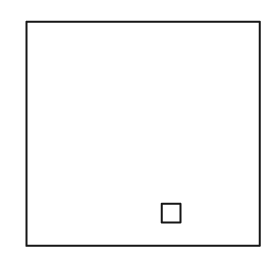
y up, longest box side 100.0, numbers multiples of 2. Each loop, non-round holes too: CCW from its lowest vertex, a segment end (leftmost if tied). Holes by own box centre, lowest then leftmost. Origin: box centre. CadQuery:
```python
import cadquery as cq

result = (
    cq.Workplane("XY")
    .moveTo(-50.0, -48.0)
    .lineTo(50.0, -48.0)
    .lineTo(50.0, 48.0)
    .lineTo(-50.0, 48.0)
    .close()
    .moveTo(8.0, -38.0)
    .lineTo(16.0, -38.0)
    .lineTo(16.0, -30.0)
    .lineTo(8.0, -30.0)
    .close()
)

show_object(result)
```